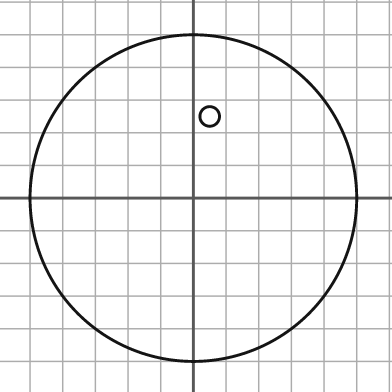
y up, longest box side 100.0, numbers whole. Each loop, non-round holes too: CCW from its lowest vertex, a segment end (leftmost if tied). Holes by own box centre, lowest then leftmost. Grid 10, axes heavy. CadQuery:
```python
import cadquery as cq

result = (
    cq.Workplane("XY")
    .moveTo(0.0, 0.0)
    .circle(50.0)
    .moveTo(5.0, 25.0)
    .circle(3.0)
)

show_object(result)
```